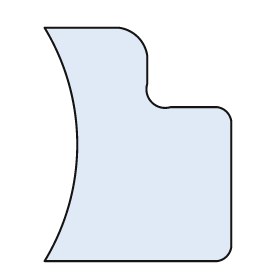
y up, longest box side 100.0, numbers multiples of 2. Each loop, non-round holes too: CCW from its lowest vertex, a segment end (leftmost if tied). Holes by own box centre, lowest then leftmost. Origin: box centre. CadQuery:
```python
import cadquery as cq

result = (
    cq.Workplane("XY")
    .moveTo(-40.0, -50.0)
    .lineTo(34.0, -50.0)
    .threePointArc((38.0, -48.0), (40.0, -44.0))
    .lineTo(40.0, 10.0)
    .threePointArc((38.0, 14.0), (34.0, 16.0))
    .lineTo(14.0, 16.0)
    .threePointArc((6.0, 18.0), (4.0, 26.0))
    .lineTo(4.0, 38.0)
    .threePointArc((0.0, 46.0), (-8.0, 50.0))
    .lineTo(-40.0, 50.0)
    .threePointArc((-26.0, 0.0), (-40.0, -50.0))
    .close()
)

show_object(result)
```